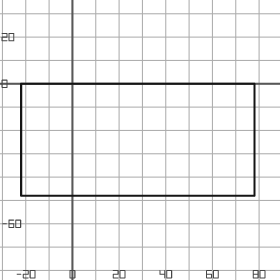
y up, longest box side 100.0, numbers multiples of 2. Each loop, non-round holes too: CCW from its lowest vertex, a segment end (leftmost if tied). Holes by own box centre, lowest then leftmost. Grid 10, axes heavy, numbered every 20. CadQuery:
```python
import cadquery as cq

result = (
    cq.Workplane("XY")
    .moveTo(-22.0, -48.0)
    .lineTo(78.0, -48.0)
    .lineTo(78.0, 0.0)
    .lineTo(-22.0, 0.0)
    .close()
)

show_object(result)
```